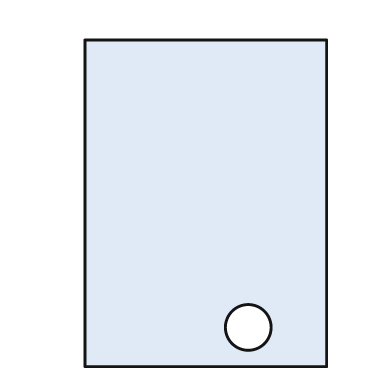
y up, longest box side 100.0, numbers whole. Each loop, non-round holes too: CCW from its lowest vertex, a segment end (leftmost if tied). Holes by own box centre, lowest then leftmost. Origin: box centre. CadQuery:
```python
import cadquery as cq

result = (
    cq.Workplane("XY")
    .moveTo(-37.0, -50.0)
    .lineTo(37.0, -50.0)
    .lineTo(37.0, 50.0)
    .lineTo(-37.0, 50.0)
    .close()
    .moveTo(13.0, -38.0)
    .circle(7.0)
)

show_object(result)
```